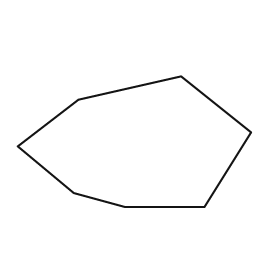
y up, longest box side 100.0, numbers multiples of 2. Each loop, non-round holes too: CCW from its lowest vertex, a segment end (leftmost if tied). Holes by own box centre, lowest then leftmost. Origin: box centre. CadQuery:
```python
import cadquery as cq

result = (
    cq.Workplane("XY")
    .moveTo(-4.0, -28.0)
    .lineTo(30.0, -28.0)
    .lineTo(50.0, 4.0)
    .lineTo(20.0, 28.0)
    .lineTo(-24.0, 18.0)
    .lineTo(-50.0, -2.0)
    .lineTo(-26.0, -22.0)
    .close()
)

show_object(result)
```